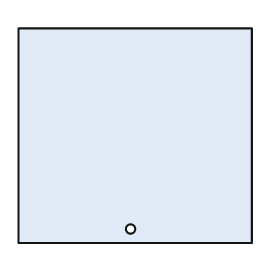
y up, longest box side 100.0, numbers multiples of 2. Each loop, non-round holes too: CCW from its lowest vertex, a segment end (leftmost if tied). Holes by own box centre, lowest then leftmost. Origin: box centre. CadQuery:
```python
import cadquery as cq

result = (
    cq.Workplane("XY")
    .moveTo(-50.0, -46.0)
    .lineTo(50.0, -46.0)
    .lineTo(50.0, 46.0)
    .lineTo(-50.0, 46.0)
    .close()
    .moveTo(-2.0, -40.0)
    .circle(2.0)
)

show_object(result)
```